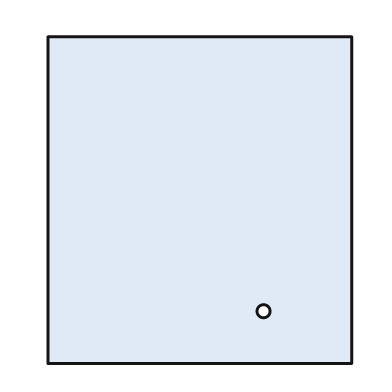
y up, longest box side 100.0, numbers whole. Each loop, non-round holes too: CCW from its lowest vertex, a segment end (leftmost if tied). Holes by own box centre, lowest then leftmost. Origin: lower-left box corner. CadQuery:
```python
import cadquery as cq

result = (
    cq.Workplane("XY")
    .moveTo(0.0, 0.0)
    .lineTo(93.0, 0.0)
    .lineTo(93.0, 100.0)
    .lineTo(0.0, 100.0)
    .close()
    .moveTo(66.0, 16.0)
    .circle(2.0)
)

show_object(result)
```